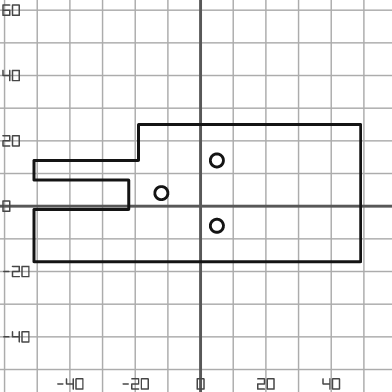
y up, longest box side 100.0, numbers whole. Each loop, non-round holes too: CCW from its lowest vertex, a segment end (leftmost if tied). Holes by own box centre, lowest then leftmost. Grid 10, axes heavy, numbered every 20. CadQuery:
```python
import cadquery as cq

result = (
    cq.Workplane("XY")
    .moveTo(-51.0, -17.0)
    .lineTo(49.0, -17.0)
    .lineTo(49.0, 25.0)
    .lineTo(-19.0, 25.0)
    .lineTo(-19.0, 14.0)
    .lineTo(-51.0, 14.0)
    .lineTo(-51.0, 8.0)
    .lineTo(-22.0, 8.0)
    .lineTo(-22.0, -1.0)
    .lineTo(-51.0, -1.0)
    .close()
    .moveTo(5.0, -6.0)
    .circle(2.0)
    .moveTo(-12.0, 4.0)
    .circle(2.0)
    .moveTo(5.0, 14.0)
    .circle(2.0)
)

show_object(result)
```